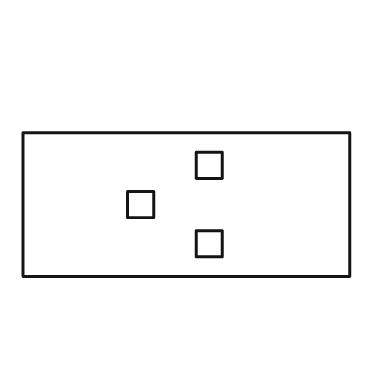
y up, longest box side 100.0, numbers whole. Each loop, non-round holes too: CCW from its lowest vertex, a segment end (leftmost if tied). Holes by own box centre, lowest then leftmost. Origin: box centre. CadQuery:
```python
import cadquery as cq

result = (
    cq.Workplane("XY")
    .moveTo(-50.0, -22.0)
    .lineTo(50.0, -22.0)
    .lineTo(50.0, 22.0)
    .lineTo(-50.0, 22.0)
    .close()
    .moveTo(3.0, -16.0)
    .lineTo(11.0, -16.0)
    .lineTo(11.0, -8.0)
    .lineTo(3.0, -8.0)
    .close()
    .moveTo(-18.0, -4.0)
    .lineTo(-10.0, -4.0)
    .lineTo(-10.0, 4.0)
    .lineTo(-18.0, 4.0)
    .close()
    .moveTo(3.0, 8.0)
    .lineTo(11.0, 8.0)
    .lineTo(11.0, 16.0)
    .lineTo(3.0, 16.0)
    .close()
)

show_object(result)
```